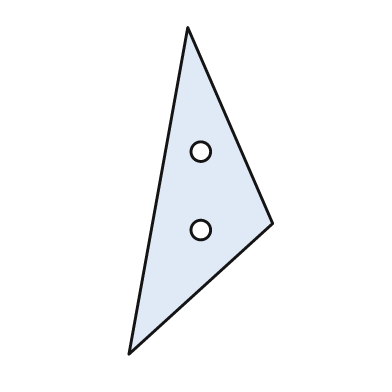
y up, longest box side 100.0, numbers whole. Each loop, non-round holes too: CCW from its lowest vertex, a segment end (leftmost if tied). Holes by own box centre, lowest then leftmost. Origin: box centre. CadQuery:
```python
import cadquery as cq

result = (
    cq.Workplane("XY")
    .moveTo(-22.0, -50.0)
    .lineTo(22.0, -10.0)
    .lineTo(-4.0, 50.0)
    .close()
    .moveTo(0.0, -12.0)
    .circle(3.0)
    .moveTo(0.0, 12.0)
    .circle(3.0)
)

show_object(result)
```